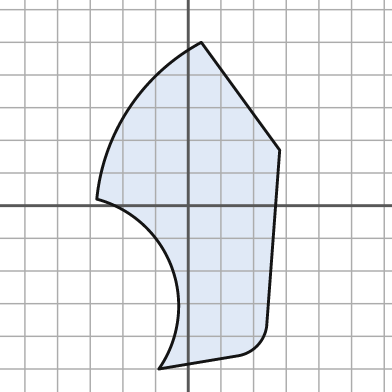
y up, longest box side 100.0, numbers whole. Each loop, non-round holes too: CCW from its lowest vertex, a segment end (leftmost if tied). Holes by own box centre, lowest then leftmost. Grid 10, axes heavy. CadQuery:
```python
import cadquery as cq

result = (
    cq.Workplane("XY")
    .moveTo(-9.0, -50.0)
    .lineTo(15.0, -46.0)
    .threePointArc((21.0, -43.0), (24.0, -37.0))
    .lineTo(28.0, 17.0)
    .lineTo(4.0, 50.0)
    .threePointArc((-18.0, 30.0), (-28.0, 2.0))
    .threePointArc((-5.0, -19.0), (-9.0, -50.0))
    .close()
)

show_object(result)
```